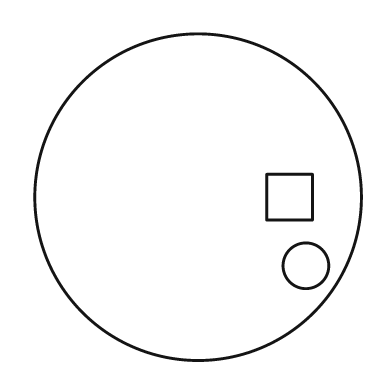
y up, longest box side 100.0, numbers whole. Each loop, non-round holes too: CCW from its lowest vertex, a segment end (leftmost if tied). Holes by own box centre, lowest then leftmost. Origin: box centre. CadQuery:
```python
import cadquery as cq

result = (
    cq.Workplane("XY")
    .moveTo(0.0, 0.0)
    .circle(50.0)
    .moveTo(33.0, -21.0)
    .circle(7.0)
    .moveTo(21.0, -7.0)
    .lineTo(35.0, -7.0)
    .lineTo(35.0, 7.0)
    .lineTo(21.0, 7.0)
    .close()
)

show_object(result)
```